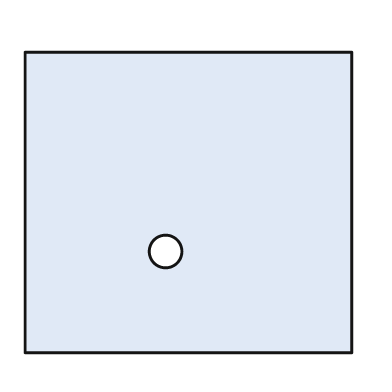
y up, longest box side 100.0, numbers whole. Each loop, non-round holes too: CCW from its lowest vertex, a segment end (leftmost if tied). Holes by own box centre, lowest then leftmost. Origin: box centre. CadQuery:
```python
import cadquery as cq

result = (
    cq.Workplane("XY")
    .moveTo(-50.0, -46.0)
    .lineTo(50.0, -46.0)
    .lineTo(50.0, 46.0)
    .lineTo(-50.0, 46.0)
    .close()
    .moveTo(-7.0, -15.0)
    .circle(5.0)
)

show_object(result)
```